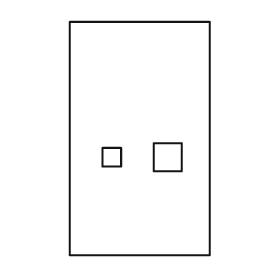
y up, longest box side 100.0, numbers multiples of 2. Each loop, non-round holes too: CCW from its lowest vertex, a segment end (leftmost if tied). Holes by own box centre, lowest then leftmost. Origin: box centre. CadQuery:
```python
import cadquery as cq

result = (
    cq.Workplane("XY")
    .moveTo(-30.0, -50.0)
    .lineTo(30.0, -50.0)
    .lineTo(30.0, 50.0)
    .lineTo(-30.0, 50.0)
    .close()
    .moveTo(-16.0, -12.0)
    .lineTo(-8.0, -12.0)
    .lineTo(-8.0, -4.0)
    .lineTo(-16.0, -4.0)
    .close()
    .moveTo(6.0, -14.0)
    .lineTo(18.0, -14.0)
    .lineTo(18.0, -2.0)
    .lineTo(6.0, -2.0)
    .close()
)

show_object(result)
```